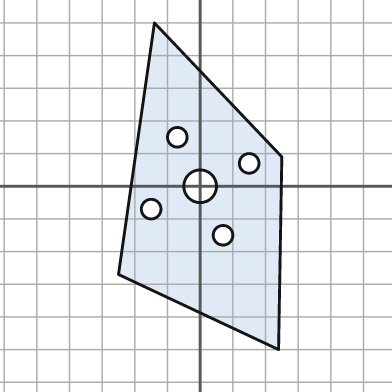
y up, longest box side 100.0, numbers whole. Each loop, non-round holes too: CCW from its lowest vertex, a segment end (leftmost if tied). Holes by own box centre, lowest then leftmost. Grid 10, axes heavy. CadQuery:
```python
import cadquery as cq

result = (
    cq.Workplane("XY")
    .moveTo(24.0, -50.0)
    .lineTo(25.0, 9.0)
    .lineTo(-14.0, 50.0)
    .lineTo(-25.0, -27.0)
    .close()
    .moveTo(7.0, -15.0)
    .circle(3.0)
    .moveTo(-15.0, -7.0)
    .circle(3.0)
    .moveTo(0.0, 0.0)
    .circle(5.0)
    .moveTo(15.0, 7.0)
    .circle(3.0)
    .moveTo(-7.0, 15.0)
    .circle(3.0)
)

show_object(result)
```